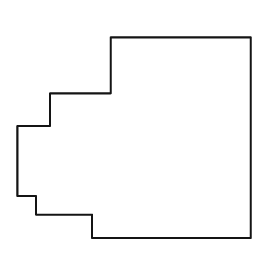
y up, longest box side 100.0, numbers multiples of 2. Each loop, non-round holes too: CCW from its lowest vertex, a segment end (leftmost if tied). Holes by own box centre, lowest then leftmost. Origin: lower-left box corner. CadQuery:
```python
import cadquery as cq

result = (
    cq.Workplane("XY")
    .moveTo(32.0, 0.0)
    .lineTo(100.0, 0.0)
    .lineTo(100.0, 86.0)
    .lineTo(40.0, 86.0)
    .lineTo(40.0, 62.0)
    .lineTo(14.0, 62.0)
    .lineTo(14.0, 48.0)
    .lineTo(0.0, 48.0)
    .lineTo(0.0, 18.0)
    .lineTo(8.0, 18.0)
    .lineTo(8.0, 10.0)
    .lineTo(32.0, 10.0)
    .close()
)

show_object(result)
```